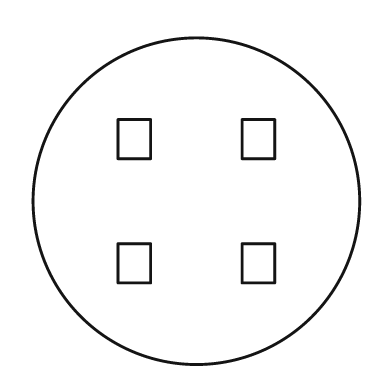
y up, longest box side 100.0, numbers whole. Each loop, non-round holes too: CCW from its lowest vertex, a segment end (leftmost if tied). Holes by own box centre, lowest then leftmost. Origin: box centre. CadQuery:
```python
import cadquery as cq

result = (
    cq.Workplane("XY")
    .moveTo(0.0, 0.0)
    .circle(50.0)
    .moveTo(-24.0, -25.0)
    .lineTo(-14.0, -25.0)
    .lineTo(-14.0, -13.0)
    .lineTo(-24.0, -13.0)
    .close()
    .moveTo(14.0, -25.0)
    .lineTo(24.0, -25.0)
    .lineTo(24.0, -13.0)
    .lineTo(14.0, -13.0)
    .close()
    .moveTo(-24.0, 13.0)
    .lineTo(-14.0, 13.0)
    .lineTo(-14.0, 25.0)
    .lineTo(-24.0, 25.0)
    .close()
    .moveTo(14.0, 13.0)
    .lineTo(24.0, 13.0)
    .lineTo(24.0, 25.0)
    .lineTo(14.0, 25.0)
    .close()
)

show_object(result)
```